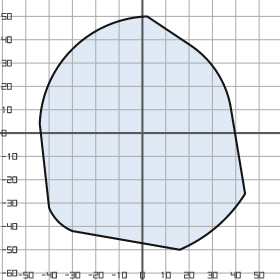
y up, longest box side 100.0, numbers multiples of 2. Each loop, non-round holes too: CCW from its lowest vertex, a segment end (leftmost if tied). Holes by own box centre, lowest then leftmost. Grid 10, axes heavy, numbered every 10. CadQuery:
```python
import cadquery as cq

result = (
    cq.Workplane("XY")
    .moveTo(16.0, -50.0)
    .threePointArc((32.0, -40.0), (44.0, -26.0))
    .lineTo(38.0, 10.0)
    .threePointArc((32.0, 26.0), (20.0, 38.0))
    .lineTo(2.0, 50.0)
    .threePointArc((-30.0, 36.0), (-44.0, 4.0))
    .lineTo(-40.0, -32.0)
    .threePointArc((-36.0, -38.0), (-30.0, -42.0))
    .close()
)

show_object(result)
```